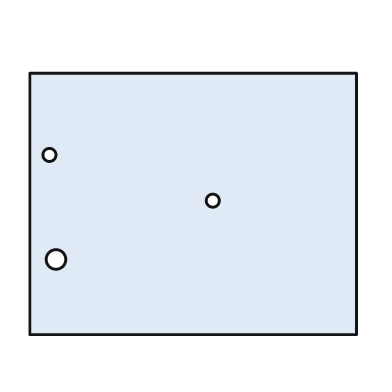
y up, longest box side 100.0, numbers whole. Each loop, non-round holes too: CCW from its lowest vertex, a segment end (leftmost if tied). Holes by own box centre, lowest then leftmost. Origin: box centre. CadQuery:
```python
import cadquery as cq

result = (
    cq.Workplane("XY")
    .moveTo(-50.0, -40.0)
    .lineTo(50.0, -40.0)
    .lineTo(50.0, 40.0)
    .lineTo(-50.0, 40.0)
    .close()
    .moveTo(-42.0, -17.0)
    .circle(3.0)
    .moveTo(6.0, 1.0)
    .circle(2.0)
    .moveTo(-44.0, 15.0)
    .circle(2.0)
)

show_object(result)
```